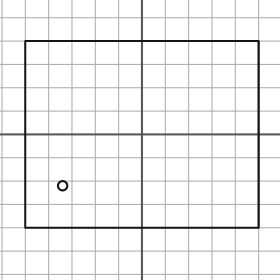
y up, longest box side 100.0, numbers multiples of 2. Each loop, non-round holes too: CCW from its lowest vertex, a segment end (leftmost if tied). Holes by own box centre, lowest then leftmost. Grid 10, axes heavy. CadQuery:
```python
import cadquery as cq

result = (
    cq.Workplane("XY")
    .moveTo(-50.0, -40.0)
    .lineTo(50.0, -40.0)
    .lineTo(50.0, 40.0)
    .lineTo(-50.0, 40.0)
    .close()
    .moveTo(-34.0, -22.0)
    .circle(2.0)
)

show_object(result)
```